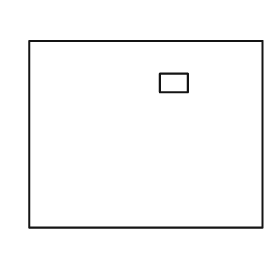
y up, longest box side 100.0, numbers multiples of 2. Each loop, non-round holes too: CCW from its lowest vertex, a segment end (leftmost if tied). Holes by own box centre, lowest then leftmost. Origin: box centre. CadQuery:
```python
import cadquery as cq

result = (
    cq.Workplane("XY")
    .moveTo(-50.0, -40.0)
    .lineTo(50.0, -40.0)
    .lineTo(50.0, 40.0)
    .lineTo(-50.0, 40.0)
    .close()
    .moveTo(6.0, 18.0)
    .lineTo(18.0, 18.0)
    .lineTo(18.0, 26.0)
    .lineTo(6.0, 26.0)
    .close()
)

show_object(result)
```